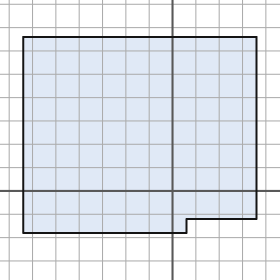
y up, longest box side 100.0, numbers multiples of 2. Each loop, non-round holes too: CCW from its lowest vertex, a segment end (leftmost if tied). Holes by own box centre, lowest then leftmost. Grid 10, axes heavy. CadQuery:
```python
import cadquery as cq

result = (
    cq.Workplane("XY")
    .moveTo(-64.0, -18.0)
    .lineTo(6.0, -18.0)
    .lineTo(6.0, -12.0)
    .lineTo(36.0, -12.0)
    .lineTo(36.0, 66.0)
    .lineTo(-64.0, 66.0)
    .close()
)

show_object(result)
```